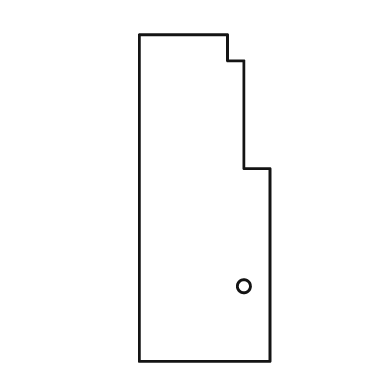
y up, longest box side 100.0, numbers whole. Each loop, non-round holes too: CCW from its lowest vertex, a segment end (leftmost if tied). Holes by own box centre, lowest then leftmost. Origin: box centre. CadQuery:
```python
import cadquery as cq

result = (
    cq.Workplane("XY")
    .moveTo(-20.0, -50.0)
    .lineTo(20.0, -50.0)
    .lineTo(20.0, 9.0)
    .lineTo(12.0, 9.0)
    .lineTo(12.0, 42.0)
    .lineTo(7.0, 42.0)
    .lineTo(7.0, 50.0)
    .lineTo(-20.0, 50.0)
    .close()
    .moveTo(12.0, -27.0)
    .circle(2.0)
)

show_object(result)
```